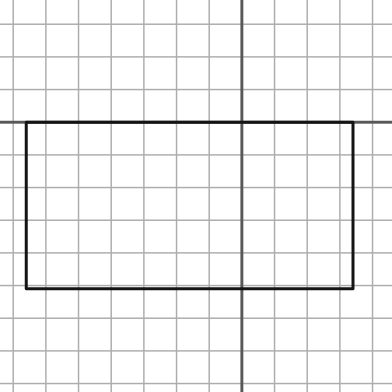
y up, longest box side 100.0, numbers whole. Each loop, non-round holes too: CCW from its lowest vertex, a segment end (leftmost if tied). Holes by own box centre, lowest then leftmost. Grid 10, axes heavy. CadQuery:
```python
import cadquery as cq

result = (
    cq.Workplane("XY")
    .moveTo(-66.0, -51.0)
    .lineTo(34.0, -51.0)
    .lineTo(34.0, 0.0)
    .lineTo(-66.0, 0.0)
    .close()
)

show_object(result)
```